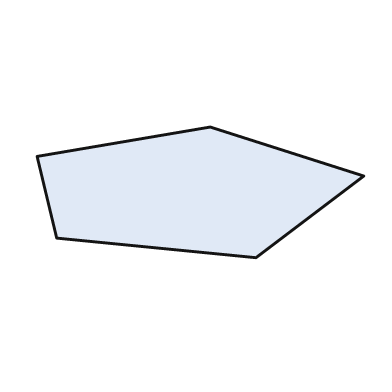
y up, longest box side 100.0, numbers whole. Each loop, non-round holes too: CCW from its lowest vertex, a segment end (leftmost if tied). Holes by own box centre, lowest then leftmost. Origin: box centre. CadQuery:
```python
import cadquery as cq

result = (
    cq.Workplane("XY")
    .moveTo(17.0, -20.0)
    .lineTo(50.0, 5.0)
    .lineTo(3.0, 20.0)
    .lineTo(-50.0, 11.0)
    .lineTo(-44.0, -14.0)
    .close()
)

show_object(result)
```